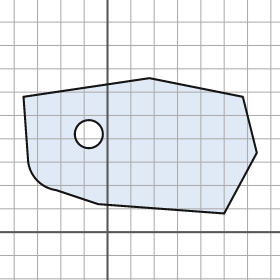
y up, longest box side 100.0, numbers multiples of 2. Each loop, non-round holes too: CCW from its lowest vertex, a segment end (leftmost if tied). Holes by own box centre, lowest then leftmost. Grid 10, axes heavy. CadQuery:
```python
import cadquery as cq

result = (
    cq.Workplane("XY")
    .moveTo(50.0, 8.0)
    .lineTo(64.0, 34.0)
    .lineTo(58.0, 58.0)
    .lineTo(18.0, 66.0)
    .lineTo(-36.0, 58.0)
    .lineTo(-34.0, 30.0)
    .threePointArc((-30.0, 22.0), (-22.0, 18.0))
    .lineTo(-4.0, 12.0)
    .close()
    .moveTo(-8.0, 42.0)
    .circle(6.0)
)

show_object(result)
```